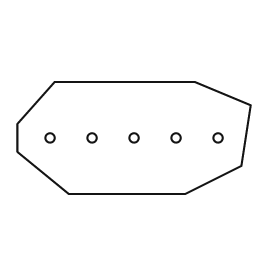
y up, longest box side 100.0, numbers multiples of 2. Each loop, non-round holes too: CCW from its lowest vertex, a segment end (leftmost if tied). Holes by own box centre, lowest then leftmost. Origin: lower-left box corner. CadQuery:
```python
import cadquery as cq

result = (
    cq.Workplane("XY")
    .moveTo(22.0, 0.0)
    .lineTo(72.0, 0.0)
    .lineTo(96.0, 12.0)
    .lineTo(100.0, 38.0)
    .lineTo(76.0, 48.0)
    .lineTo(16.0, 48.0)
    .lineTo(0.0, 30.0)
    .lineTo(0.0, 18.0)
    .close()
    .moveTo(14.0, 24.0)
    .circle(2.0)
    .moveTo(32.0, 24.0)
    .circle(2.0)
    .moveTo(50.0, 24.0)
    .circle(2.0)
    .moveTo(68.0, 24.0)
    .circle(2.0)
    .moveTo(86.0, 24.0)
    .circle(2.0)
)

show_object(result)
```